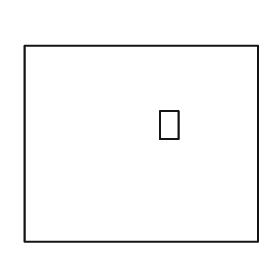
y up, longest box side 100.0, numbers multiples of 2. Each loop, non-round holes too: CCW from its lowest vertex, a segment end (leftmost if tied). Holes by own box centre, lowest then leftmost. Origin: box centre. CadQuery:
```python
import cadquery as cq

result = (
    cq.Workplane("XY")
    .moveTo(-50.0, -42.0)
    .lineTo(50.0, -42.0)
    .lineTo(50.0, 42.0)
    .lineTo(-50.0, 42.0)
    .close()
    .moveTo(8.0, 2.0)
    .lineTo(16.0, 2.0)
    .lineTo(16.0, 14.0)
    .lineTo(8.0, 14.0)
    .close()
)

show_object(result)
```